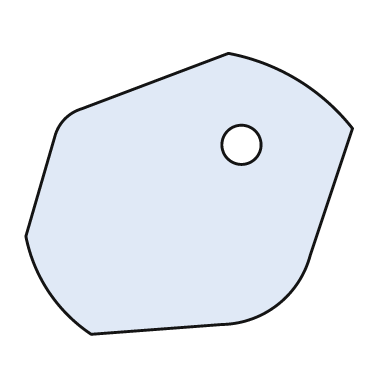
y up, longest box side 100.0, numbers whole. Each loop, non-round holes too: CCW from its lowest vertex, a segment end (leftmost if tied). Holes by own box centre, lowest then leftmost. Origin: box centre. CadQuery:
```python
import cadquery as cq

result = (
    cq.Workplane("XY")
    .moveTo(-30.0, -43.0)
    .lineTo(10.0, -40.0)
    .threePointArc((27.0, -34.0), (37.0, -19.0))
    .lineTo(50.0, 20.0)
    .threePointArc((33.0, 35.0), (12.0, 43.0))
    .lineTo(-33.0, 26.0)
    .threePointArc((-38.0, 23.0), (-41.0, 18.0))
    .lineTo(-50.0, -13.0)
    .threePointArc((-43.0, -30.0), (-30.0, -43.0))
    .close()
    .moveTo(16.0, 15.0)
    .circle(6.0)
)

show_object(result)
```